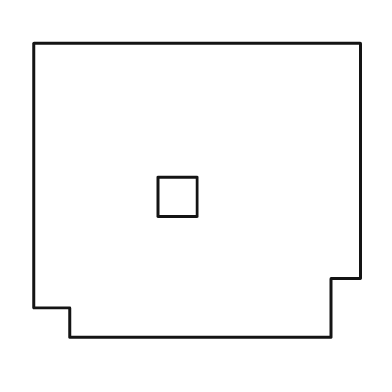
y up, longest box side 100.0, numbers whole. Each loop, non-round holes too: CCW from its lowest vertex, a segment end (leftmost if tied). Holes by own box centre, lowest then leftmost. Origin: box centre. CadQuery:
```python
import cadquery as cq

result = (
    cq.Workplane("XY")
    .moveTo(-39.0, -45.0)
    .lineTo(41.0, -45.0)
    .lineTo(41.0, -27.0)
    .lineTo(50.0, -27.0)
    .lineTo(50.0, 45.0)
    .lineTo(-50.0, 45.0)
    .lineTo(-50.0, -36.0)
    .lineTo(-39.0, -36.0)
    .close()
    .moveTo(-12.0, -8.0)
    .lineTo(0.0, -8.0)
    .lineTo(0.0, 4.0)
    .lineTo(-12.0, 4.0)
    .close()
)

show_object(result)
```